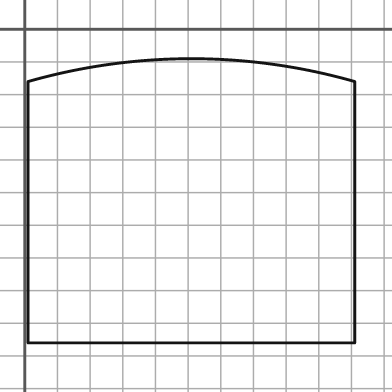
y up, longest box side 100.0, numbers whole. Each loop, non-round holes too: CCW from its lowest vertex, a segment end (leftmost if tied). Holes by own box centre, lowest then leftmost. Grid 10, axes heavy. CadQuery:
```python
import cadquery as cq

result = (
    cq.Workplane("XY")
    .moveTo(1.0, -96.0)
    .lineTo(101.0, -96.0)
    .lineTo(101.0, -16.0)
    .threePointArc((51.0, -9.0), (1.0, -16.0))
    .close()
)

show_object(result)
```